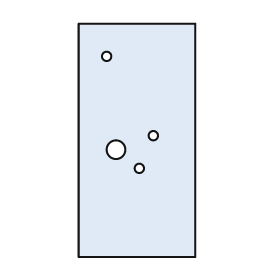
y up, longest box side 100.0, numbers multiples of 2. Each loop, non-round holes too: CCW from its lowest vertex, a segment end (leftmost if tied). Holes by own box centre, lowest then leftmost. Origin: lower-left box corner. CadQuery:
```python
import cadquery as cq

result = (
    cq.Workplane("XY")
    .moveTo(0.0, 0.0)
    .lineTo(50.0, 0.0)
    .lineTo(50.0, 100.0)
    .lineTo(0.0, 100.0)
    .close()
    .moveTo(26.0, 38.0)
    .circle(2.0)
    .moveTo(16.0, 46.0)
    .circle(4.0)
    .moveTo(32.0, 52.0)
    .circle(2.0)
    .moveTo(12.0, 86.0)
    .circle(2.0)
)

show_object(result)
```